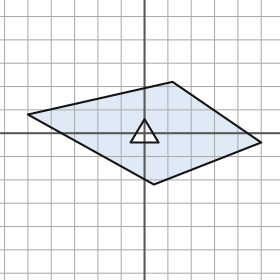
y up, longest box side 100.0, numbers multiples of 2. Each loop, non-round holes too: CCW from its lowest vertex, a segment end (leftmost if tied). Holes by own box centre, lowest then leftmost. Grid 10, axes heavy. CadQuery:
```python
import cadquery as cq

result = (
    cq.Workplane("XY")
    .moveTo(4.0, -22.0)
    .lineTo(50.0, -4.0)
    .lineTo(12.0, 22.0)
    .lineTo(-50.0, 8.0)
    .close()
    .moveTo(-6.0, -4.0)
    .lineTo(6.0, -4.0)
    .lineTo(0.0, 6.0)
    .close()
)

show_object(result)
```